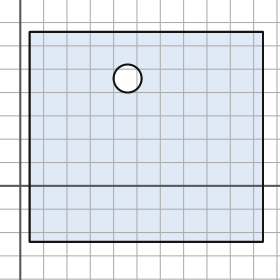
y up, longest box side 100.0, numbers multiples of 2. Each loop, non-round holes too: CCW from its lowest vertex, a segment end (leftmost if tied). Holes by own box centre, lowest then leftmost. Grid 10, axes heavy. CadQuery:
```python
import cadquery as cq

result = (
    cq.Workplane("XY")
    .moveTo(4.0, -24.0)
    .lineTo(104.0, -24.0)
    .lineTo(104.0, 66.0)
    .lineTo(4.0, 66.0)
    .close()
    .moveTo(46.0, 46.0)
    .circle(6.0)
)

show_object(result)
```